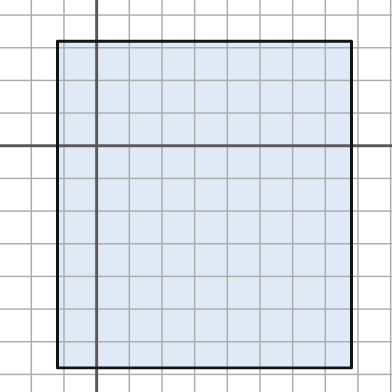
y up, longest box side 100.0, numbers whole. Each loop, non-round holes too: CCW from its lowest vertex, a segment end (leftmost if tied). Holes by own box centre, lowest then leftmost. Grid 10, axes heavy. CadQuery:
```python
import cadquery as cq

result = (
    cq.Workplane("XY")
    .moveTo(-12.0, -68.0)
    .lineTo(78.0, -68.0)
    .lineTo(78.0, 32.0)
    .lineTo(-12.0, 32.0)
    .close()
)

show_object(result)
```